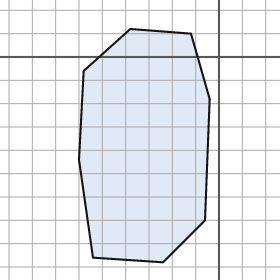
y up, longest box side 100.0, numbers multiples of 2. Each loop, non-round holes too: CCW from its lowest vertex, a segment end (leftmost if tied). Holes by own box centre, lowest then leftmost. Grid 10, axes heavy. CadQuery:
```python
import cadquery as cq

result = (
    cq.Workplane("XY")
    .moveTo(-24.0, -88.0)
    .lineTo(-6.0, -70.0)
    .lineTo(-4.0, -18.0)
    .lineTo(-12.0, 10.0)
    .lineTo(-38.0, 12.0)
    .lineTo(-58.0, -6.0)
    .lineTo(-60.0, -44.0)
    .lineTo(-54.0, -86.0)
    .close()
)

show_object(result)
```